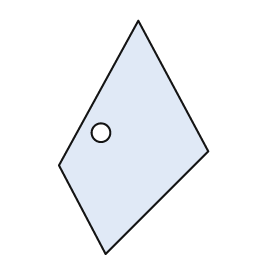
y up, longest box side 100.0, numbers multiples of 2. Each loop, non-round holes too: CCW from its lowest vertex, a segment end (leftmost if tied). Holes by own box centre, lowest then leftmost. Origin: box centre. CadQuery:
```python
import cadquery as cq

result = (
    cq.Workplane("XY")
    .moveTo(-12.0, -50.0)
    .lineTo(32.0, -6.0)
    .lineTo(2.0, 50.0)
    .lineTo(-32.0, -12.0)
    .close()
    .moveTo(-14.0, 2.0)
    .circle(4.0)
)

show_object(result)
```